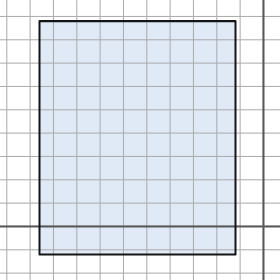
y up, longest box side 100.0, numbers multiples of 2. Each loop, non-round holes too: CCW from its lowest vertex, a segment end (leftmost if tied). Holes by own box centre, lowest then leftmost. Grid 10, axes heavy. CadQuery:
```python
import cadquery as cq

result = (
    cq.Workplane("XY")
    .moveTo(-96.0, -12.0)
    .lineTo(-12.0, -12.0)
    .lineTo(-12.0, 88.0)
    .lineTo(-96.0, 88.0)
    .close()
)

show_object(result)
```